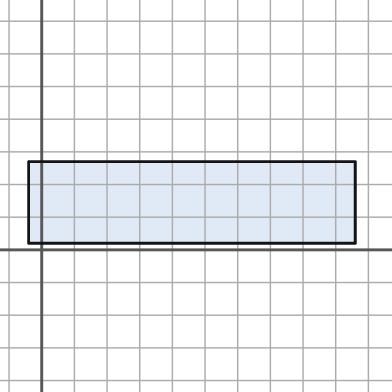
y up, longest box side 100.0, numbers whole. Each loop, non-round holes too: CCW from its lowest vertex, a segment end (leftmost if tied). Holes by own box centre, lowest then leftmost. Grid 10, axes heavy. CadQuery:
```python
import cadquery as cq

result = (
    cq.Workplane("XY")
    .moveTo(-4.0, 2.0)
    .lineTo(96.0, 2.0)
    .lineTo(96.0, 27.0)
    .lineTo(-4.0, 27.0)
    .close()
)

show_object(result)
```